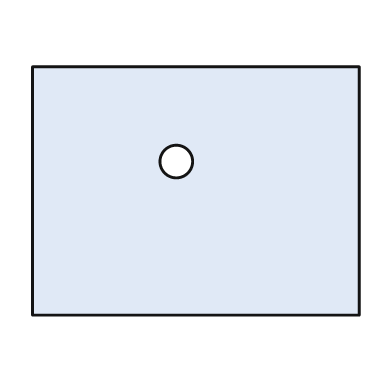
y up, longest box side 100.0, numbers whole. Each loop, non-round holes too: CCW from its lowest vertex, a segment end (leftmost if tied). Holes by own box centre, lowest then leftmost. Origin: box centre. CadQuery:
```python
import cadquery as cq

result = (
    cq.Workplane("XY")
    .moveTo(-50.0, -38.0)
    .lineTo(50.0, -38.0)
    .lineTo(50.0, 38.0)
    .lineTo(-50.0, 38.0)
    .close()
    .moveTo(-6.0, 9.0)
    .circle(5.0)
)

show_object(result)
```